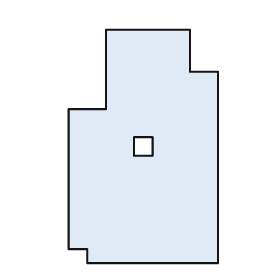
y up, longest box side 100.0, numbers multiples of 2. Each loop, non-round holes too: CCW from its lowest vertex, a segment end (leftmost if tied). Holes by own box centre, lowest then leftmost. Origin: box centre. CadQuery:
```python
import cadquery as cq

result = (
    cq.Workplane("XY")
    .moveTo(-24.0, -50.0)
    .lineTo(32.0, -50.0)
    .lineTo(32.0, 32.0)
    .lineTo(20.0, 32.0)
    .lineTo(20.0, 50.0)
    .lineTo(-16.0, 50.0)
    .lineTo(-16.0, 16.0)
    .lineTo(-32.0, 16.0)
    .lineTo(-32.0, -44.0)
    .lineTo(-24.0, -44.0)
    .close()
    .moveTo(-4.0, -4.0)
    .lineTo(4.0, -4.0)
    .lineTo(4.0, 4.0)
    .lineTo(-4.0, 4.0)
    .close()
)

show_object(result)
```